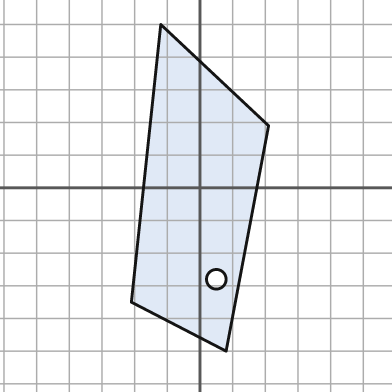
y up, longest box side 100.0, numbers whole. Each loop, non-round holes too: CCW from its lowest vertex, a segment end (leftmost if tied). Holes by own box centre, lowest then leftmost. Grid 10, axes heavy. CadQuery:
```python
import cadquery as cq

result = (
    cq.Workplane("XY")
    .moveTo(8.0, -50.0)
    .lineTo(21.0, 19.0)
    .lineTo(-12.0, 50.0)
    .lineTo(-21.0, -35.0)
    .close()
    .moveTo(5.0, -28.0)
    .circle(3.0)
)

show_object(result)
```